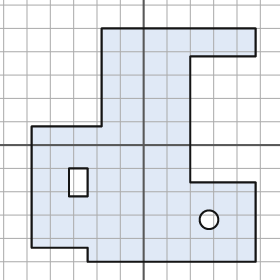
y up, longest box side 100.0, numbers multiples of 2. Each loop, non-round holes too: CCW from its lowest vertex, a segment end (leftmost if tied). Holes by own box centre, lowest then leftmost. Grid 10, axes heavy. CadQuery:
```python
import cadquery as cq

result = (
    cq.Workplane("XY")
    .moveTo(-24.0, -50.0)
    .lineTo(48.0, -50.0)
    .lineTo(48.0, -16.0)
    .lineTo(20.0, -16.0)
    .lineTo(20.0, 38.0)
    .lineTo(48.0, 38.0)
    .lineTo(48.0, 50.0)
    .lineTo(-18.0, 50.0)
    .lineTo(-18.0, 8.0)
    .lineTo(-48.0, 8.0)
    .lineTo(-48.0, -44.0)
    .lineTo(-24.0, -44.0)
    .close()
    .moveTo(28.0, -32.0)
    .circle(4.0)
    .moveTo(-32.0, -22.0)
    .lineTo(-24.0, -22.0)
    .lineTo(-24.0, -10.0)
    .lineTo(-32.0, -10.0)
    .close()
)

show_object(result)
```